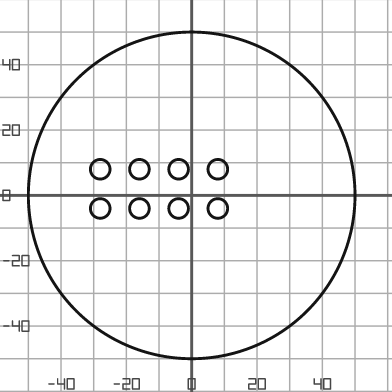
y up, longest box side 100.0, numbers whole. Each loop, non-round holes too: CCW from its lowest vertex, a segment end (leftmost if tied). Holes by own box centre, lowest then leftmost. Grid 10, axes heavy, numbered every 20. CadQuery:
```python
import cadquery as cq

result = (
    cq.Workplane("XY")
    .moveTo(0.0, 0.0)
    .circle(50.0)
    .moveTo(-28.0, -4.0)
    .circle(3.0)
    .moveTo(-16.0, -4.0)
    .circle(3.0)
    .moveTo(-4.0, -4.0)
    .circle(3.0)
    .moveTo(8.0, -4.0)
    .circle(3.0)
    .moveTo(-28.0, 8.0)
    .circle(3.0)
    .moveTo(-16.0, 8.0)
    .circle(3.0)
    .moveTo(-4.0, 8.0)
    .circle(3.0)
    .moveTo(8.0, 8.0)
    .circle(3.0)
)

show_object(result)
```